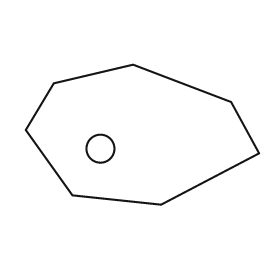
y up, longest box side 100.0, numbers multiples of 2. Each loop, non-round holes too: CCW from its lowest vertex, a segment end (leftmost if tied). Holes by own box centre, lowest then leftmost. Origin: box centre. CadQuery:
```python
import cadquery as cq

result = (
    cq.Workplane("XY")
    .moveTo(8.0, -30.0)
    .lineTo(50.0, -8.0)
    .lineTo(38.0, 14.0)
    .lineTo(-4.0, 30.0)
    .lineTo(-38.0, 22.0)
    .lineTo(-50.0, 2.0)
    .lineTo(-30.0, -26.0)
    .close()
    .moveTo(-18.0, -6.0)
    .circle(6.0)
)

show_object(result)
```